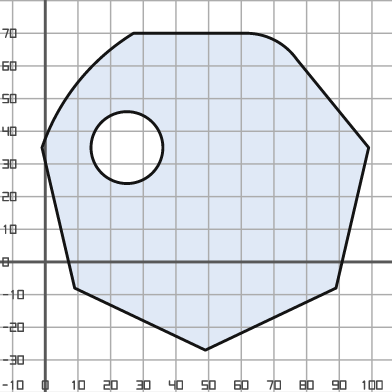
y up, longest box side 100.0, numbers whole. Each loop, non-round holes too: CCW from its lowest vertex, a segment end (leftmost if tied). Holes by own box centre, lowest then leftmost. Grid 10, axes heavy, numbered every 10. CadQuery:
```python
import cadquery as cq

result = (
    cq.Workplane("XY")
    .moveTo(49.0, -27.0)
    .lineTo(89.0, -8.0)
    .lineTo(99.0, 35.0)
    .lineTo(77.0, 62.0)
    .threePointArc((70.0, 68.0), (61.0, 70.0))
    .lineTo(27.0, 70.0)
    .threePointArc((10.0, 55.0), (-1.0, 35.0))
    .lineTo(9.0, -8.0)
    .close()
    .moveTo(25.0, 35.0)
    .circle(11.0)
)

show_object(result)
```